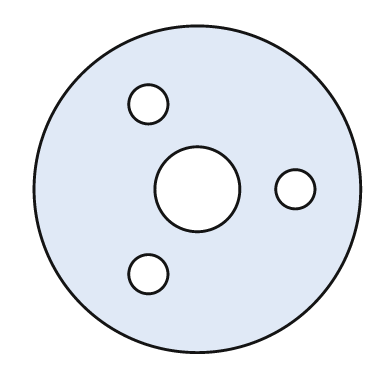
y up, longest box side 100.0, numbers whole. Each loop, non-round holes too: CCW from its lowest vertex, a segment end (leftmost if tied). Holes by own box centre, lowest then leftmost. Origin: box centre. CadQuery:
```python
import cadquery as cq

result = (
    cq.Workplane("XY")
    .moveTo(0.0, 0.0)
    .circle(50.0)
    .moveTo(-15.0, -26.0)
    .circle(6.0)
    .moveTo(0.0, 0.0)
    .circle(13.0)
    .moveTo(30.0, 0.0)
    .circle(6.0)
    .moveTo(-15.0, 26.0)
    .circle(6.0)
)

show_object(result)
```